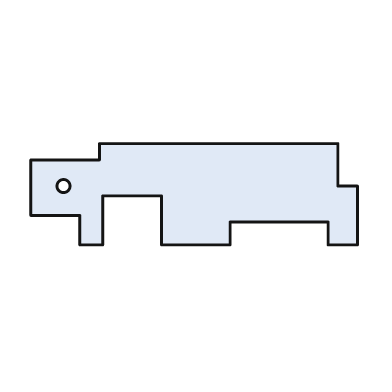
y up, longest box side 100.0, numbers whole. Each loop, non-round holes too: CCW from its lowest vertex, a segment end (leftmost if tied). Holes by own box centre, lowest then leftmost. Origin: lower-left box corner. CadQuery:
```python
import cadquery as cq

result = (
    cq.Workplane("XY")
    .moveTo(15.0, 0.0)
    .lineTo(22.0, 0.0)
    .lineTo(22.0, 15.0)
    .lineTo(40.0, 15.0)
    .lineTo(40.0, 0.0)
    .lineTo(61.0, 0.0)
    .lineTo(61.0, 7.0)
    .lineTo(91.0, 7.0)
    .lineTo(91.0, 0.0)
    .lineTo(100.0, 0.0)
    .lineTo(100.0, 18.0)
    .lineTo(94.0, 18.0)
    .lineTo(94.0, 31.0)
    .lineTo(21.0, 31.0)
    .lineTo(21.0, 26.0)
    .lineTo(0.0, 26.0)
    .lineTo(0.0, 9.0)
    .lineTo(15.0, 9.0)
    .close()
    .moveTo(10.0, 18.0)
    .circle(2.0)
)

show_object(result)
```